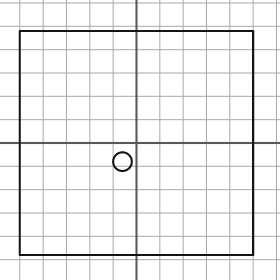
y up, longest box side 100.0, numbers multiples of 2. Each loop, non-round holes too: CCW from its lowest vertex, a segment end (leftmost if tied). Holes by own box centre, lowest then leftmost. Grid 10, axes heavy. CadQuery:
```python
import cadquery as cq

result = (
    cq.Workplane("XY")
    .moveTo(-50.0, -48.0)
    .lineTo(50.0, -48.0)
    .lineTo(50.0, 48.0)
    .lineTo(-50.0, 48.0)
    .close()
    .moveTo(-6.0, -8.0)
    .circle(4.0)
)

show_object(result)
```